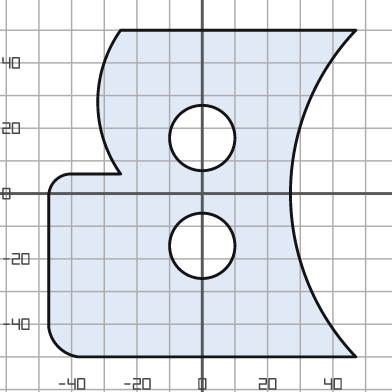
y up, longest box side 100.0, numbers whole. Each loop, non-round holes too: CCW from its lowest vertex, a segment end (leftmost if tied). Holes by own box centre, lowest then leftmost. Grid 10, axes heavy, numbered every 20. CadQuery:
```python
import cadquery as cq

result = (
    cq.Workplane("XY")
    .moveTo(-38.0, -50.0)
    .lineTo(47.0, -50.0)
    .threePointArc((27.0, 0.0), (47.0, 50.0))
    .lineTo(-25.0, 50.0)
    .threePointArc((-32.0, 28.0), (-25.0, 6.0))
    .lineTo(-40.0, 6.0)
    .threePointArc((-45.0, 4.0), (-47.0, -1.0))
    .lineTo(-47.0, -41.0)
    .threePointArc((-44.0, -47.0), (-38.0, -50.0))
    .close()
    .moveTo(0.0, -16.0)
    .circle(10.0)
    .moveTo(0.0, 17.0)
    .circle(10.0)
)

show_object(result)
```